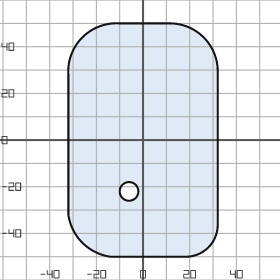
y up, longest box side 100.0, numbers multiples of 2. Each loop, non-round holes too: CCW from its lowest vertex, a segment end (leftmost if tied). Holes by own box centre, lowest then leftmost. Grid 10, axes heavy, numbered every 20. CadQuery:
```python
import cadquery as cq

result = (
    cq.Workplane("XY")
    .moveTo(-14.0, -50.0)
    .lineTo(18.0, -50.0)
    .threePointArc((28.0, -46.0), (32.0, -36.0))
    .lineTo(32.0, 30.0)
    .threePointArc((26.0, 44.0), (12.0, 50.0))
    .lineTo(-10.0, 50.0)
    .threePointArc((-26.0, 44.0), (-32.0, 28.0))
    .lineTo(-32.0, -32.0)
    .threePointArc((-26.0, -44.0), (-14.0, -50.0))
    .close()
    .moveTo(-6.0, -22.0)
    .circle(4.0)
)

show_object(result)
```